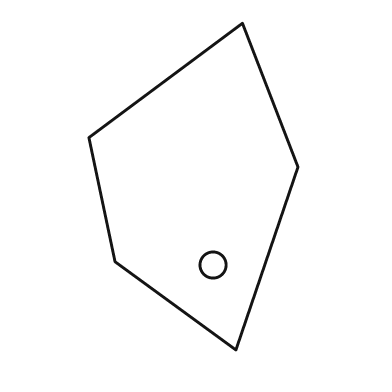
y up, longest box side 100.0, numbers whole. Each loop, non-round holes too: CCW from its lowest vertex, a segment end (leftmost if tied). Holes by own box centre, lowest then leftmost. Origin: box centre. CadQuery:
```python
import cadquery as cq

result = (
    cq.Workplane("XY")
    .moveTo(13.0, -50.0)
    .lineTo(32.0, 6.0)
    .lineTo(15.0, 50.0)
    .lineTo(-32.0, 15.0)
    .lineTo(-24.0, -23.0)
    .close()
    .moveTo(6.0, -24.0)
    .circle(4.0)
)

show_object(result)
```